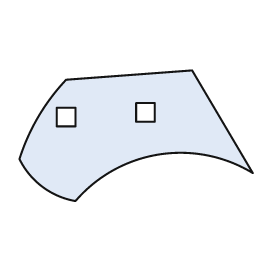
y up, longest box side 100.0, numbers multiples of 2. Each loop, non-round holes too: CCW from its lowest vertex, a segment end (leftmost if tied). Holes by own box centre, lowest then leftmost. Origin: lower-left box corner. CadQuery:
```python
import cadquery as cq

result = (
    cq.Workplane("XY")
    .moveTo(24.0, 0.0)
    .threePointArc((60.0, 20.0), (100.0, 12.0))
    .lineTo(74.0, 56.0)
    .lineTo(20.0, 52.0)
    .threePointArc((8.0, 36.0), (0.0, 18.0))
    .threePointArc((10.0, 6.0), (24.0, 0.0))
    .close()
    .moveTo(16.0, 32.0)
    .lineTo(24.0, 32.0)
    .lineTo(24.0, 40.0)
    .lineTo(16.0, 40.0)
    .close()
    .moveTo(50.0, 34.0)
    .lineTo(58.0, 34.0)
    .lineTo(58.0, 42.0)
    .lineTo(50.0, 42.0)
    .close()
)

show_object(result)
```